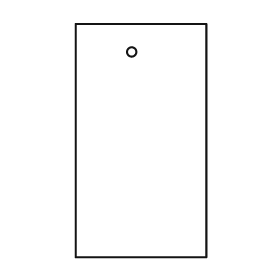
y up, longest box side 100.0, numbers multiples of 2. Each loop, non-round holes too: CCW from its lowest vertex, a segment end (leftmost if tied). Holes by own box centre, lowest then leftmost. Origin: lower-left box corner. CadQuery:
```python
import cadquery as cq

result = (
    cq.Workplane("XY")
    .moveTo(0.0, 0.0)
    .lineTo(56.0, 0.0)
    .lineTo(56.0, 100.0)
    .lineTo(0.0, 100.0)
    .close()
    .moveTo(24.0, 88.0)
    .circle(2.0)
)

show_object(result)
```